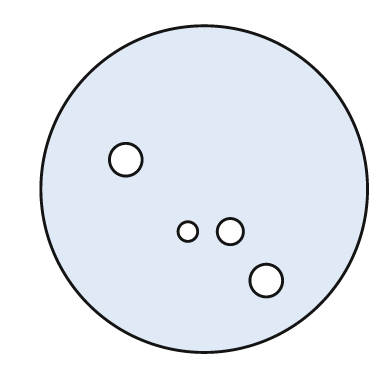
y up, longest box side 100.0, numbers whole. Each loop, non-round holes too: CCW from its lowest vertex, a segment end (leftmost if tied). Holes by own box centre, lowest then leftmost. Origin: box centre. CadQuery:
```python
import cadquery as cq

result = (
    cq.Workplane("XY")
    .moveTo(0.0, 0.0)
    .circle(50.0)
    .moveTo(19.0, -28.0)
    .circle(5.0)
    .moveTo(-5.0, -13.0)
    .circle(3.0)
    .moveTo(8.0, -13.0)
    .circle(4.0)
    .moveTo(-24.0, 9.0)
    .circle(5.0)
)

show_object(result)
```